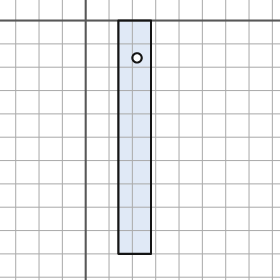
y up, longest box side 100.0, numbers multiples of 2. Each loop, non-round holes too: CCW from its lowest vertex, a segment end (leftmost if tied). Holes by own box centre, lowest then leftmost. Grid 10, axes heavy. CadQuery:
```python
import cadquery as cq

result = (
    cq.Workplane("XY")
    .moveTo(14.0, -100.0)
    .lineTo(28.0, -100.0)
    .lineTo(28.0, 0.0)
    .lineTo(14.0, 0.0)
    .close()
    .moveTo(22.0, -16.0)
    .circle(2.0)
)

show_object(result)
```